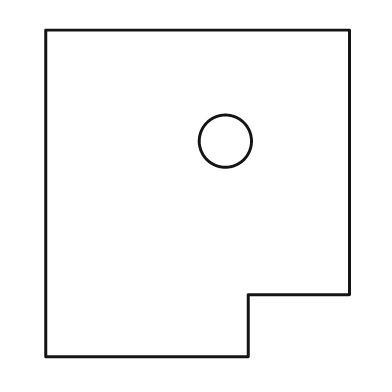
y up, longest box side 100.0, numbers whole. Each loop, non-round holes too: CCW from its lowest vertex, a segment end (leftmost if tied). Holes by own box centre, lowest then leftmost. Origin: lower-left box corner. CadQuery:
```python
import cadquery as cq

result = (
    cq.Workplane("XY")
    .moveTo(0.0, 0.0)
    .lineTo(62.0, 0.0)
    .lineTo(62.0, 19.0)
    .lineTo(93.0, 19.0)
    .lineTo(93.0, 100.0)
    .lineTo(0.0, 100.0)
    .close()
    .moveTo(55.0, 66.0)
    .circle(8.0)
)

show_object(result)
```